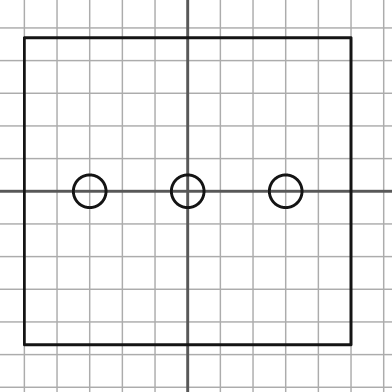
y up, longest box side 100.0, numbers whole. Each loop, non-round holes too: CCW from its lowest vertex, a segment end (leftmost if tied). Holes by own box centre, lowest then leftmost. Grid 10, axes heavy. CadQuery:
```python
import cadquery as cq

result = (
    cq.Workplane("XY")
    .moveTo(-50.0, -47.0)
    .lineTo(50.0, -47.0)
    .lineTo(50.0, 47.0)
    .lineTo(-50.0, 47.0)
    .close()
    .moveTo(-30.0, 0.0)
    .circle(5.0)
    .moveTo(0.0, 0.0)
    .circle(5.0)
    .moveTo(30.0, 0.0)
    .circle(5.0)
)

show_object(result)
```